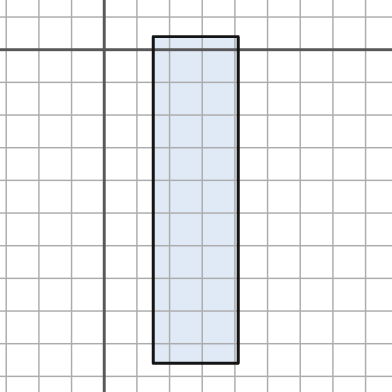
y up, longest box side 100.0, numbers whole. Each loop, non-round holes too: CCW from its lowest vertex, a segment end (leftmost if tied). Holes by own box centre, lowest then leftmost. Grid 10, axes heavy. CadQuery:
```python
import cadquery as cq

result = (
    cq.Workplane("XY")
    .moveTo(15.0, -96.0)
    .lineTo(41.0, -96.0)
    .lineTo(41.0, 4.0)
    .lineTo(15.0, 4.0)
    .close()
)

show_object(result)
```